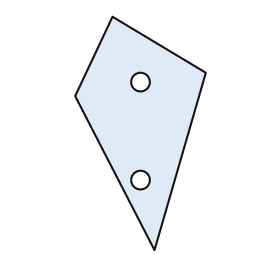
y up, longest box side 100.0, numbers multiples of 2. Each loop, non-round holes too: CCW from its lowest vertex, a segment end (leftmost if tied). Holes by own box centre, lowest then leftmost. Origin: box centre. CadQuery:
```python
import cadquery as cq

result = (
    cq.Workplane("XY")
    .moveTo(6.0, -50.0)
    .lineTo(28.0, 26.0)
    .lineTo(-12.0, 50.0)
    .lineTo(-28.0, 16.0)
    .close()
    .moveTo(0.0, -20.0)
    .circle(4.0)
    .moveTo(0.0, 22.0)
    .circle(4.0)
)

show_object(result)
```